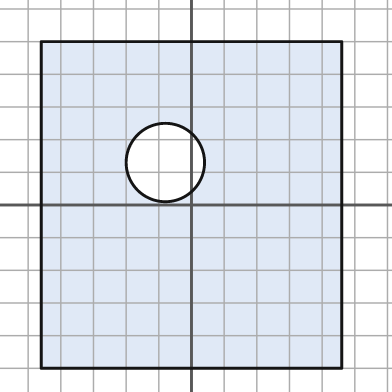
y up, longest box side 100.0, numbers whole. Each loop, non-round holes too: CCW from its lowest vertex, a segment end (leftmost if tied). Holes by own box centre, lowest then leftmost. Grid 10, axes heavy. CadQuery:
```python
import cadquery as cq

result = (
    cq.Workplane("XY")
    .moveTo(-46.0, -50.0)
    .lineTo(46.0, -50.0)
    .lineTo(46.0, 50.0)
    .lineTo(-46.0, 50.0)
    .close()
    .moveTo(-8.0, 13.0)
    .circle(12.0)
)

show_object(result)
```